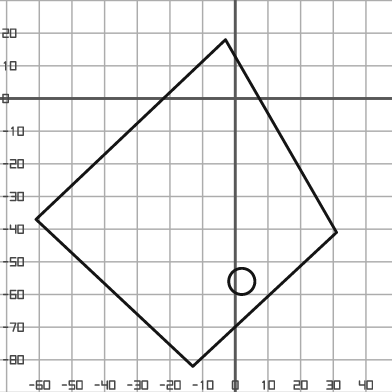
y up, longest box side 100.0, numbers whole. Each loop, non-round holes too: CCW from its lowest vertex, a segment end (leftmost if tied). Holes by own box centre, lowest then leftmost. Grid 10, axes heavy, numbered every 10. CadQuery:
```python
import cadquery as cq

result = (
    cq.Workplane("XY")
    .moveTo(-13.0, -82.0)
    .lineTo(31.0, -41.0)
    .lineTo(-3.0, 18.0)
    .lineTo(-61.0, -37.0)
    .close()
    .moveTo(2.0, -56.0)
    .circle(4.0)
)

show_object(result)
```